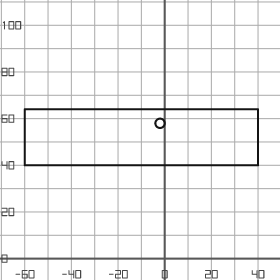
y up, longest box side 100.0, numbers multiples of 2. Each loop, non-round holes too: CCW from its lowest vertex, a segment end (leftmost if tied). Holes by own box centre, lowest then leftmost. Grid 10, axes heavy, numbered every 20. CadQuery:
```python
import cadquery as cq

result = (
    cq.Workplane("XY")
    .moveTo(-60.0, 40.0)
    .lineTo(40.0, 40.0)
    .lineTo(40.0, 64.0)
    .lineTo(-60.0, 64.0)
    .close()
    .moveTo(-2.0, 58.0)
    .circle(2.0)
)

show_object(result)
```